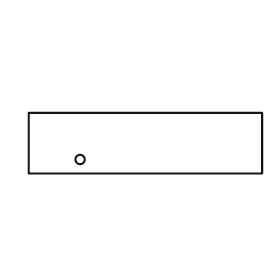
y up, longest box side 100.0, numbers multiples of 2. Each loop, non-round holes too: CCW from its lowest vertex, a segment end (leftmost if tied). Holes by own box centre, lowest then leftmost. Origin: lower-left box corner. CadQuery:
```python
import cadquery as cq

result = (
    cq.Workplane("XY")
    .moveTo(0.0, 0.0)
    .lineTo(100.0, 0.0)
    .lineTo(100.0, 26.0)
    .lineTo(0.0, 26.0)
    .close()
    .moveTo(22.0, 6.0)
    .circle(2.0)
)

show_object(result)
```